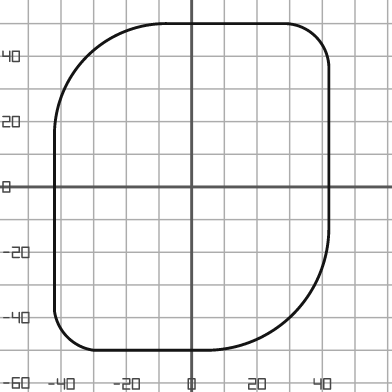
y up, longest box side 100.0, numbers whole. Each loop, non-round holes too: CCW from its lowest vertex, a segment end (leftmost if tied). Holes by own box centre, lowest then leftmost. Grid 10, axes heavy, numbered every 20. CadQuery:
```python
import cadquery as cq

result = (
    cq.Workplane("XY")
    .moveTo(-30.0, -50.0)
    .lineTo(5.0, -50.0)
    .threePointArc((31.0, -39.0), (42.0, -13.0))
    .lineTo(42.0, 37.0)
    .threePointArc((38.0, 46.0), (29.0, 50.0))
    .lineTo(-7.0, 50.0)
    .threePointArc((-32.0, 40.0), (-42.0, 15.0))
    .lineTo(-42.0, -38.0)
    .threePointArc((-38.0, -46.0), (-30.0, -50.0))
    .close()
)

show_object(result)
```